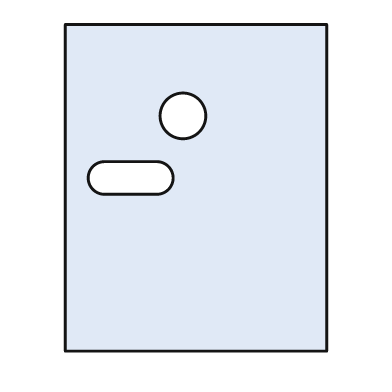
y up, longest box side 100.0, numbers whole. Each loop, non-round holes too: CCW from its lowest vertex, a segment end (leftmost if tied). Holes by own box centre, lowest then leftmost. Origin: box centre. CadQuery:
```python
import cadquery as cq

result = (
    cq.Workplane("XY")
    .moveTo(-40.0, -50.0)
    .lineTo(40.0, -50.0)
    .lineTo(40.0, 50.0)
    .lineTo(-40.0, 50.0)
    .close()
    .moveTo(-28.0, -2.0)
    .lineTo(-12.0, -2.0)
    .threePointArc((-7.0, 3.0), (-12.0, 8.0))
    .lineTo(-28.0, 8.0)
    .threePointArc((-33.0, 3.0), (-28.0, -2.0))
    .close()
    .moveTo(-4.0, 22.0)
    .circle(7.0)
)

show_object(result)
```